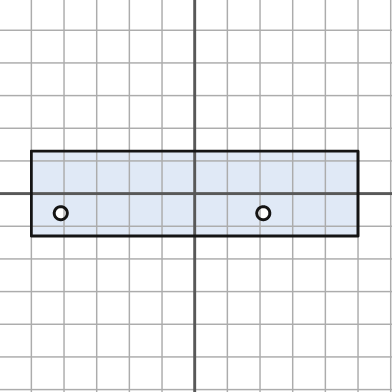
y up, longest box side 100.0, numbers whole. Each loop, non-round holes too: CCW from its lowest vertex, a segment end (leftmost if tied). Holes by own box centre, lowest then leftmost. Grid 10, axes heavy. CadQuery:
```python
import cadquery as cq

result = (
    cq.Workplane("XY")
    .moveTo(-50.0, -13.0)
    .lineTo(50.0, -13.0)
    .lineTo(50.0, 13.0)
    .lineTo(-50.0, 13.0)
    .close()
    .moveTo(-41.0, -6.0)
    .circle(2.0)
    .moveTo(21.0, -6.0)
    .circle(2.0)
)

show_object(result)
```